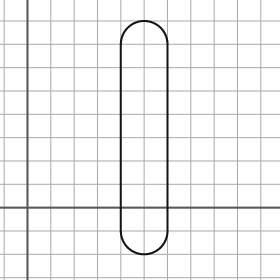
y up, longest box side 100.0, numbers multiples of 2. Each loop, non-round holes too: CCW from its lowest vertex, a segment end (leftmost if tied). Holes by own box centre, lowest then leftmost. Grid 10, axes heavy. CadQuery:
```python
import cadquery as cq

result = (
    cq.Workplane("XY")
    .moveTo(40.0, -10.0)
    .threePointArc((50.0, -20.0), (60.0, -10.0))
    .lineTo(60.0, 70.0)
    .threePointArc((50.0, 80.0), (40.0, 70.0))
    .close()
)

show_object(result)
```